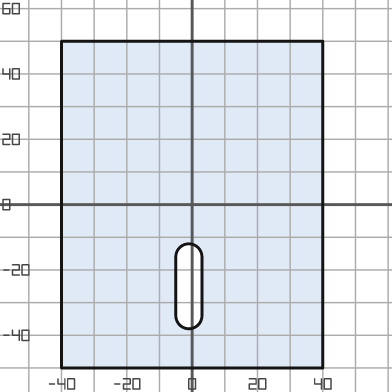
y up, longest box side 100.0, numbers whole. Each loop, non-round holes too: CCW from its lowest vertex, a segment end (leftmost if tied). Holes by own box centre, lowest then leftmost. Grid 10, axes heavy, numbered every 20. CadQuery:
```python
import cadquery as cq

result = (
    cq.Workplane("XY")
    .moveTo(-40.0, -50.0)
    .lineTo(40.0, -50.0)
    .lineTo(40.0, 50.0)
    .lineTo(-40.0, 50.0)
    .close()
    .moveTo(-5.0, -34.0)
    .threePointArc((-1.0, -38.0), (3.0, -34.0))
    .lineTo(3.0, -16.0)
    .threePointArc((-1.0, -12.0), (-5.0, -16.0))
    .close()
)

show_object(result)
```